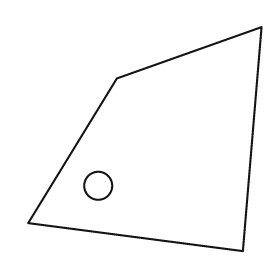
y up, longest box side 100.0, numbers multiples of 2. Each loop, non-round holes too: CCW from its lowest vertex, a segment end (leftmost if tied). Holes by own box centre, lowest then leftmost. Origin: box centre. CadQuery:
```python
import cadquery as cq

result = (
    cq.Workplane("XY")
    .moveTo(42.0, -48.0)
    .lineTo(50.0, 48.0)
    .lineTo(-12.0, 26.0)
    .lineTo(-50.0, -36.0)
    .close()
    .moveTo(-20.0, -20.0)
    .circle(6.0)
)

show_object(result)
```